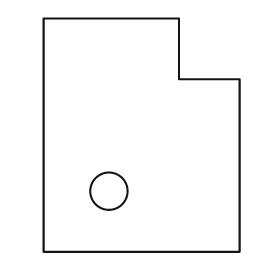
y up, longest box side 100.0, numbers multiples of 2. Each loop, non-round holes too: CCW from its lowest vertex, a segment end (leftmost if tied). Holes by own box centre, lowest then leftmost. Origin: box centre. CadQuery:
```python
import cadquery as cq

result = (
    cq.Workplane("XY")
    .moveTo(-42.0, -50.0)
    .lineTo(42.0, -50.0)
    .lineTo(42.0, 24.0)
    .lineTo(16.0, 24.0)
    .lineTo(16.0, 50.0)
    .lineTo(-42.0, 50.0)
    .close()
    .moveTo(-14.0, -24.0)
    .circle(8.0)
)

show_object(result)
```